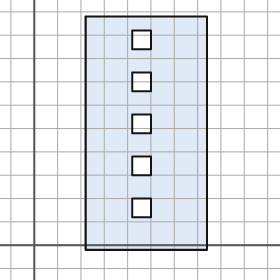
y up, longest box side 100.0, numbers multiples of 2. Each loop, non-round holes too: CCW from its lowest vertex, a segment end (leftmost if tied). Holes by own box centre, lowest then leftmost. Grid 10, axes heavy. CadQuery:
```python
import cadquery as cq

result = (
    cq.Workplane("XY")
    .moveTo(22.0, -2.0)
    .lineTo(74.0, -2.0)
    .lineTo(74.0, 98.0)
    .lineTo(22.0, 98.0)
    .close()
    .moveTo(42.0, 12.0)
    .lineTo(50.0, 12.0)
    .lineTo(50.0, 20.0)
    .lineTo(42.0, 20.0)
    .close()
    .moveTo(42.0, 30.0)
    .lineTo(50.0, 30.0)
    .lineTo(50.0, 38.0)
    .lineTo(42.0, 38.0)
    .close()
    .moveTo(42.0, 48.0)
    .lineTo(50.0, 48.0)
    .lineTo(50.0, 56.0)
    .lineTo(42.0, 56.0)
    .close()
    .moveTo(42.0, 66.0)
    .lineTo(50.0, 66.0)
    .lineTo(50.0, 74.0)
    .lineTo(42.0, 74.0)
    .close()
    .moveTo(42.0, 84.0)
    .lineTo(50.0, 84.0)
    .lineTo(50.0, 92.0)
    .lineTo(42.0, 92.0)
    .close()
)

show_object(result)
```